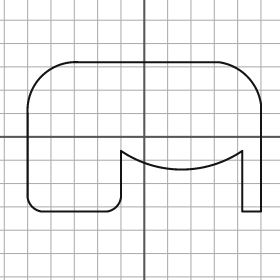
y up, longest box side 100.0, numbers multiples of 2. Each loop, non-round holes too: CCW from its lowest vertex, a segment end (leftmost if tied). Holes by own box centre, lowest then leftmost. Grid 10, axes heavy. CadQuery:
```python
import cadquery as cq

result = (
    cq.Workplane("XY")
    .moveTo(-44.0, -32.0)
    .lineTo(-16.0, -32.0)
    .threePointArc((-12.0, -30.0), (-10.0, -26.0))
    .lineTo(-10.0, -6.0)
    .threePointArc((16.0, -14.0), (42.0, -6.0))
    .lineTo(42.0, -32.0)
    .lineTo(50.0, -32.0)
    .lineTo(50.0, 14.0)
    .threePointArc((44.0, 26.0), (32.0, 32.0))
    .lineTo(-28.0, 32.0)
    .threePointArc((-44.0, 26.0), (-50.0, 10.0))
    .lineTo(-50.0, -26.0)
    .threePointArc((-48.0, -30.0), (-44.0, -32.0))
    .close()
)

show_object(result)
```